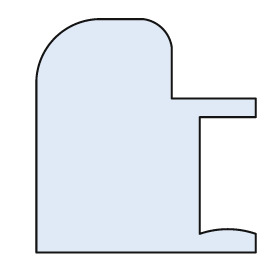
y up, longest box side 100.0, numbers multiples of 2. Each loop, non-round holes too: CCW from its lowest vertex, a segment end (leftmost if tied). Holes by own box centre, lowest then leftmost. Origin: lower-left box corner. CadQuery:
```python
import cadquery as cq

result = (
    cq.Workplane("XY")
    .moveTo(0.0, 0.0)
    .lineTo(94.0, 0.0)
    .lineTo(94.0, 8.0)
    .threePointArc((82.0, 10.0), (70.0, 8.0))
    .lineTo(70.0, 58.0)
    .lineTo(94.0, 58.0)
    .lineTo(94.0, 66.0)
    .lineTo(58.0, 66.0)
    .lineTo(58.0, 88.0)
    .threePointArc((54.0, 96.0), (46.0, 100.0))
    .lineTo(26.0, 100.0)
    .threePointArc((8.0, 92.0), (0.0, 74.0))
    .close()
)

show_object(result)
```